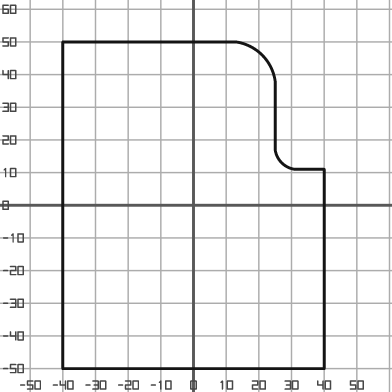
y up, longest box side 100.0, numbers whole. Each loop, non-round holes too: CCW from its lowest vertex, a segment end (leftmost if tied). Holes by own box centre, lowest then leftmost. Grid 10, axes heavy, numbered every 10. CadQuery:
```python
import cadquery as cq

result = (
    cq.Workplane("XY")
    .moveTo(-40.0, -50.0)
    .lineTo(40.0, -50.0)
    .lineTo(40.0, 11.0)
    .lineTo(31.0, 11.0)
    .threePointArc((27.0, 13.0), (25.0, 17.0))
    .lineTo(25.0, 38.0)
    .threePointArc((21.0, 46.0), (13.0, 50.0))
    .lineTo(-40.0, 50.0)
    .close()
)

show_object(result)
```